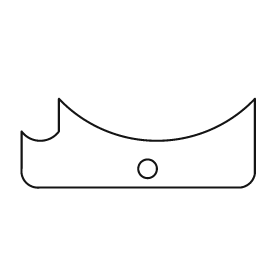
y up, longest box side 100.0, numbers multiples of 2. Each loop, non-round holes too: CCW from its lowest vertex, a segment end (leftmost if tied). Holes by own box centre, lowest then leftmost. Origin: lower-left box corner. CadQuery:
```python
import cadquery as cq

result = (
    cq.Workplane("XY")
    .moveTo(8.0, 0.0)
    .lineTo(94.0, 0.0)
    .threePointArc((98.0, 2.0), (100.0, 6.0))
    .lineTo(100.0, 38.0)
    .threePointArc((58.0, 20.0), (16.0, 38.0))
    .lineTo(16.0, 24.0)
    .threePointArc((8.0, 20.0), (0.0, 24.0))
    .lineTo(0.0, 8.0)
    .threePointArc((2.0, 2.0), (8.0, 0.0))
    .close()
    .moveTo(54.0, 8.0)
    .circle(4.0)
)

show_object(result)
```